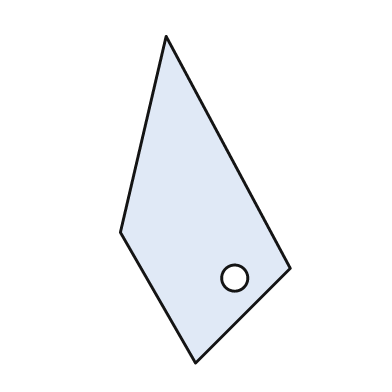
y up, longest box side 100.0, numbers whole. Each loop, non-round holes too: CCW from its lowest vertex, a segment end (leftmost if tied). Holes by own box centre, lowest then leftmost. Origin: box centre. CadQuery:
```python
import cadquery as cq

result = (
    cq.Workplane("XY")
    .moveTo(-3.0, -50.0)
    .lineTo(26.0, -21.0)
    .lineTo(-12.0, 50.0)
    .lineTo(-26.0, -10.0)
    .close()
    .moveTo(9.0, -24.0)
    .circle(4.0)
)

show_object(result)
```